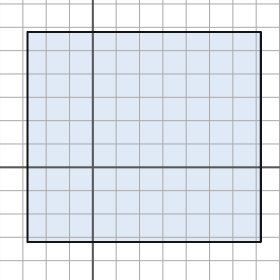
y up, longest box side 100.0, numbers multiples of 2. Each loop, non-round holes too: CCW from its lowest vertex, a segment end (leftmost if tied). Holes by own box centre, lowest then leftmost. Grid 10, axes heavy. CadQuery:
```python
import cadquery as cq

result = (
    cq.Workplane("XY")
    .moveTo(-28.0, -32.0)
    .lineTo(72.0, -32.0)
    .lineTo(72.0, 58.0)
    .lineTo(-28.0, 58.0)
    .close()
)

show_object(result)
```